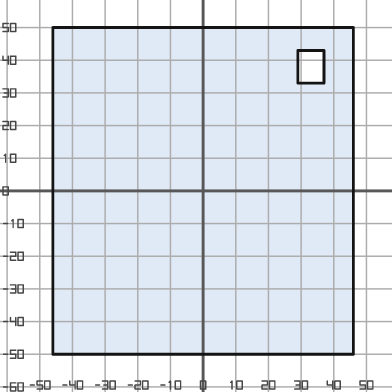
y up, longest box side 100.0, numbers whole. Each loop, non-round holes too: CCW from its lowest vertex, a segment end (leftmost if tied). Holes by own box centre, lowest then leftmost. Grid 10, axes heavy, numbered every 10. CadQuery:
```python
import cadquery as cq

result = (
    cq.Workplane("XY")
    .moveTo(-46.0, -50.0)
    .lineTo(46.0, -50.0)
    .lineTo(46.0, 50.0)
    .lineTo(-46.0, 50.0)
    .close()
    .moveTo(29.0, 33.0)
    .lineTo(37.0, 33.0)
    .lineTo(37.0, 43.0)
    .lineTo(29.0, 43.0)
    .close()
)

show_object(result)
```